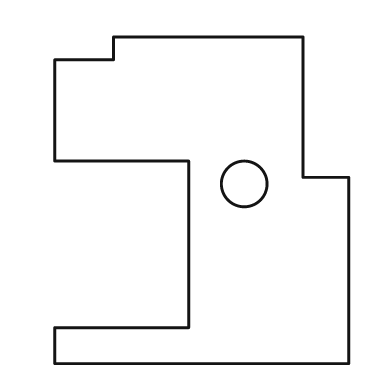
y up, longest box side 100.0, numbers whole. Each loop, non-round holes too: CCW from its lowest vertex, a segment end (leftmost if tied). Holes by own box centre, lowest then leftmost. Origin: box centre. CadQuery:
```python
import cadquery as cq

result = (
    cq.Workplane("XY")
    .moveTo(-45.0, -50.0)
    .lineTo(45.0, -50.0)
    .lineTo(45.0, 7.0)
    .lineTo(31.0, 7.0)
    .lineTo(31.0, 50.0)
    .lineTo(-27.0, 50.0)
    .lineTo(-27.0, 43.0)
    .lineTo(-45.0, 43.0)
    .lineTo(-45.0, 12.0)
    .lineTo(-4.0, 12.0)
    .lineTo(-4.0, -39.0)
    .lineTo(-45.0, -39.0)
    .close()
    .moveTo(13.0, 5.0)
    .circle(7.0)
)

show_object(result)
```